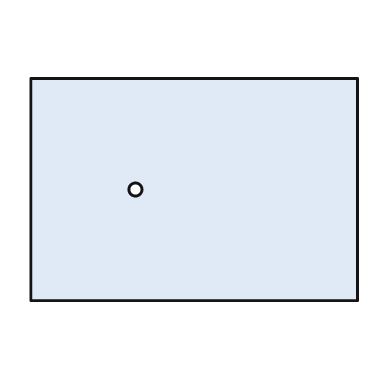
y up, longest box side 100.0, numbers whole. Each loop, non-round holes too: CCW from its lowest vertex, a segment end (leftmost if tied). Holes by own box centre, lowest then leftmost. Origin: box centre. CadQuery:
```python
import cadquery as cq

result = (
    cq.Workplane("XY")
    .moveTo(-50.0, -34.0)
    .lineTo(50.0, -34.0)
    .lineTo(50.0, 34.0)
    .lineTo(-50.0, 34.0)
    .close()
    .moveTo(-18.0, 0.0)
    .circle(2.0)
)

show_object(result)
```